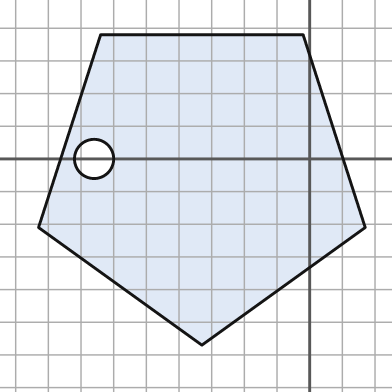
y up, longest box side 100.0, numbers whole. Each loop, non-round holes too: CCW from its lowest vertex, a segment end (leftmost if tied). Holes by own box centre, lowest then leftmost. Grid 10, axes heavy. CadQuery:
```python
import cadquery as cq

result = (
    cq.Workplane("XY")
    .moveTo(-33.0, -57.0)
    .lineTo(17.0, -21.0)
    .lineTo(-2.0, 38.0)
    .lineTo(-64.0, 38.0)
    .lineTo(-83.0, -21.0)
    .close()
    .moveTo(-66.0, 0.0)
    .circle(6.0)
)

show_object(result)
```